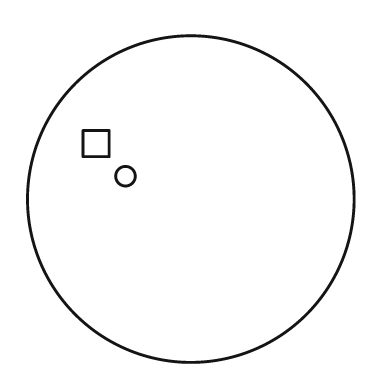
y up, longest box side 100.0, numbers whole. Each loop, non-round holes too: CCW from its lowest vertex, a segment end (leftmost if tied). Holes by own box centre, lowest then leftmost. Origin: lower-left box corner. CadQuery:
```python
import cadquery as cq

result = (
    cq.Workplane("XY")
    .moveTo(50.0, 50.0)
    .circle(50.0)
    .moveTo(30.0, 57.0)
    .circle(3.0)
    .moveTo(17.0, 63.0)
    .lineTo(25.0, 63.0)
    .lineTo(25.0, 71.0)
    .lineTo(17.0, 71.0)
    .close()
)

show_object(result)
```